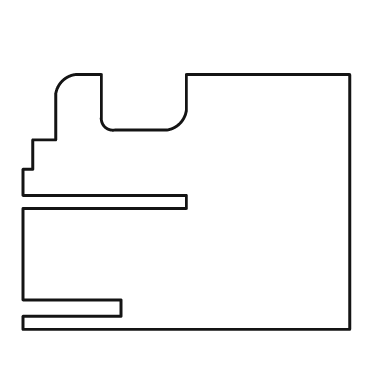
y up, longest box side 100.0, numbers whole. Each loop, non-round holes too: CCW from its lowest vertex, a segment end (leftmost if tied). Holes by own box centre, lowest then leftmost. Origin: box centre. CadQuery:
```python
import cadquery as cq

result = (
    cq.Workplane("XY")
    .moveTo(-50.0, -39.0)
    .lineTo(50.0, -39.0)
    .lineTo(50.0, 39.0)
    .lineTo(0.0, 39.0)
    .lineTo(0.0, 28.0)
    .threePointArc((-2.0, 24.0), (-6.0, 22.0))
    .lineTo(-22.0, 22.0)
    .threePointArc((-25.0, 23.0), (-26.0, 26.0))
    .lineTo(-26.0, 39.0)
    .lineTo(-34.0, 39.0)
    .threePointArc((-38.0, 37.0), (-40.0, 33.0))
    .lineTo(-40.0, 19.0)
    .lineTo(-47.0, 19.0)
    .lineTo(-47.0, 10.0)
    .lineTo(-50.0, 10.0)
    .lineTo(-50.0, 2.0)
    .lineTo(0.0, 2.0)
    .lineTo(0.0, -2.0)
    .lineTo(-50.0, -2.0)
    .lineTo(-50.0, -30.0)
    .lineTo(-20.0, -30.0)
    .lineTo(-20.0, -35.0)
    .lineTo(-50.0, -35.0)
    .close()
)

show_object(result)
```